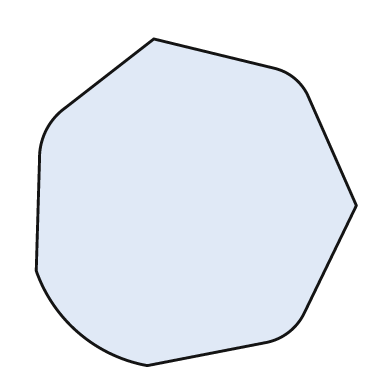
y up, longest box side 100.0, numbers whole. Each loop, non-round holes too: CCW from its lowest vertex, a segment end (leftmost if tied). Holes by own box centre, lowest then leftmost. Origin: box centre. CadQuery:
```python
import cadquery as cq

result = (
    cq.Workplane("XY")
    .moveTo(-15.0, -50.0)
    .lineTo(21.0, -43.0)
    .threePointArc((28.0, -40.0), (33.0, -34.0))
    .lineTo(49.0, -1.0)
    .lineTo(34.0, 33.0)
    .threePointArc((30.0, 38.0), (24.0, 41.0))
    .lineTo(-13.0, 50.0)
    .lineTo(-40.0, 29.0)
    .threePointArc((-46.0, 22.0), (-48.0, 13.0))
    .lineTo(-49.0, -21.0)
    .threePointArc((-36.0, -40.0), (-15.0, -50.0))
    .close()
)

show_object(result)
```